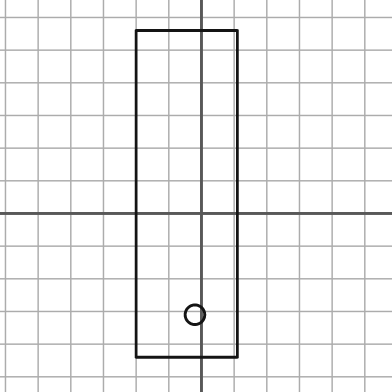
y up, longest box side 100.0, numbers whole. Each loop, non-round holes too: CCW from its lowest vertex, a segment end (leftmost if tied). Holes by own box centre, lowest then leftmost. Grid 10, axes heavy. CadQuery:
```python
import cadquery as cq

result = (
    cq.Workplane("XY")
    .moveTo(-20.0, -44.0)
    .lineTo(11.0, -44.0)
    .lineTo(11.0, 56.0)
    .lineTo(-20.0, 56.0)
    .close()
    .moveTo(-2.0, -31.0)
    .circle(3.0)
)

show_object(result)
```